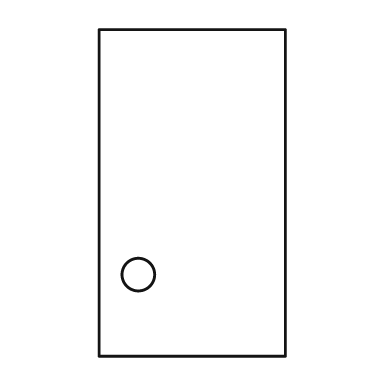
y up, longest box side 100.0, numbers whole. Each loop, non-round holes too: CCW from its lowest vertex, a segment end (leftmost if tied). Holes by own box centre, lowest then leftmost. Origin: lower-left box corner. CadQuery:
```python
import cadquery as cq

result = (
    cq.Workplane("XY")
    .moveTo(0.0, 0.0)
    .lineTo(57.0, 0.0)
    .lineTo(57.0, 100.0)
    .lineTo(0.0, 100.0)
    .close()
    .moveTo(12.0, 25.0)
    .circle(5.0)
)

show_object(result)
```